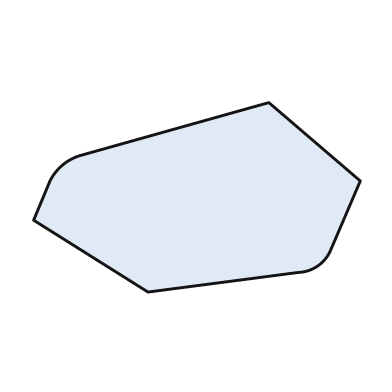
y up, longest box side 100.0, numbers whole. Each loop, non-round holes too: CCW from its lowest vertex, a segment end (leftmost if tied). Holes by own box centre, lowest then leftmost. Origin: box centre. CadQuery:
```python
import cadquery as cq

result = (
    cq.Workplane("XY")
    .moveTo(-15.0, -29.0)
    .lineTo(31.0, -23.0)
    .threePointArc((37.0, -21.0), (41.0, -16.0))
    .lineTo(50.0, 5.0)
    .lineTo(22.0, 29.0)
    .lineTo(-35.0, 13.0)
    .threePointArc((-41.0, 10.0), (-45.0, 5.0))
    .lineTo(-50.0, -7.0)
    .close()
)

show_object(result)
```